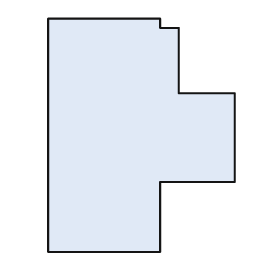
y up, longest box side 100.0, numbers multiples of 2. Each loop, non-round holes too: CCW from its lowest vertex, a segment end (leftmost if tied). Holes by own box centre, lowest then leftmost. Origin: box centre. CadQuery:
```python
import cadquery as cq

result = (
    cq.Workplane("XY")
    .moveTo(-40.0, -50.0)
    .lineTo(8.0, -50.0)
    .lineTo(8.0, -20.0)
    .lineTo(40.0, -20.0)
    .lineTo(40.0, 18.0)
    .lineTo(16.0, 18.0)
    .lineTo(16.0, 46.0)
    .lineTo(8.0, 46.0)
    .lineTo(8.0, 50.0)
    .lineTo(-40.0, 50.0)
    .close()
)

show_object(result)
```